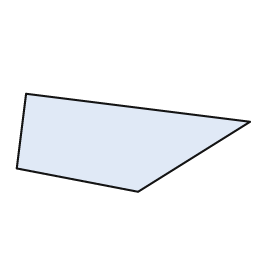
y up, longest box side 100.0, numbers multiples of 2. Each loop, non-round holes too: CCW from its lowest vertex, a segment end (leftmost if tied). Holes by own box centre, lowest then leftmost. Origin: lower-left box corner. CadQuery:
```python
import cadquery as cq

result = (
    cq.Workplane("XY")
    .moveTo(52.0, 0.0)
    .lineTo(100.0, 30.0)
    .lineTo(4.0, 42.0)
    .lineTo(0.0, 10.0)
    .close()
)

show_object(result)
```